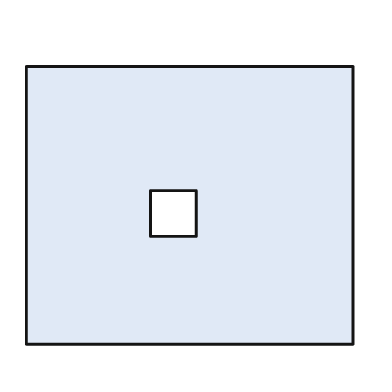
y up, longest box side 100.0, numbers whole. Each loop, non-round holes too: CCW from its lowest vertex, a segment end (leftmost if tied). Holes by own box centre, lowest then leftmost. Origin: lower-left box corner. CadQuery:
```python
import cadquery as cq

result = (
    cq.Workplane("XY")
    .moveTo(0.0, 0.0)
    .lineTo(100.0, 0.0)
    .lineTo(100.0, 85.0)
    .lineTo(0.0, 85.0)
    .close()
    .moveTo(38.0, 33.0)
    .lineTo(52.0, 33.0)
    .lineTo(52.0, 47.0)
    .lineTo(38.0, 47.0)
    .close()
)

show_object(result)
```